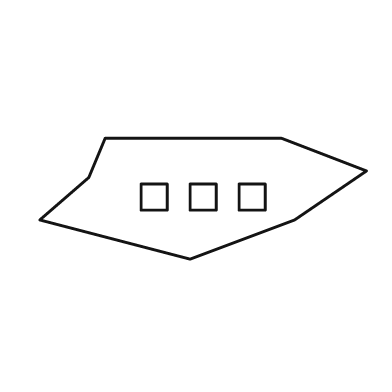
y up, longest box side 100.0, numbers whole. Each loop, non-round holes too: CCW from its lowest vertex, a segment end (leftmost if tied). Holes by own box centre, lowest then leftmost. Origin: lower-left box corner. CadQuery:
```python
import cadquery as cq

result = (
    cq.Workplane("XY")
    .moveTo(46.0, 0.0)
    .lineTo(78.0, 12.0)
    .lineTo(100.0, 27.0)
    .lineTo(74.0, 37.0)
    .lineTo(20.0, 37.0)
    .lineTo(15.0, 25.0)
    .lineTo(0.0, 12.0)
    .close()
    .moveTo(31.0, 15.0)
    .lineTo(39.0, 15.0)
    .lineTo(39.0, 23.0)
    .lineTo(31.0, 23.0)
    .close()
    .moveTo(46.0, 15.0)
    .lineTo(54.0, 15.0)
    .lineTo(54.0, 23.0)
    .lineTo(46.0, 23.0)
    .close()
    .moveTo(61.0, 15.0)
    .lineTo(69.0, 15.0)
    .lineTo(69.0, 23.0)
    .lineTo(61.0, 23.0)
    .close()
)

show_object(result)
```